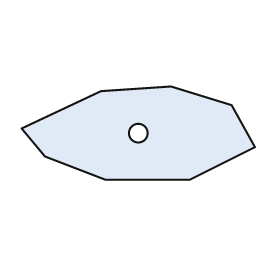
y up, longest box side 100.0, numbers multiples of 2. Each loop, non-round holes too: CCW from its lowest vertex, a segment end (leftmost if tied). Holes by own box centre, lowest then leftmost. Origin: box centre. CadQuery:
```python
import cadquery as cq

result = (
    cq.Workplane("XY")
    .moveTo(-14.0, -20.0)
    .lineTo(22.0, -20.0)
    .lineTo(50.0, -6.0)
    .lineTo(40.0, 12.0)
    .lineTo(14.0, 20.0)
    .lineTo(-16.0, 18.0)
    .lineTo(-50.0, 2.0)
    .lineTo(-40.0, -10.0)
    .close()
    .moveTo(0.0, 0.0)
    .circle(4.0)
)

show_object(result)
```